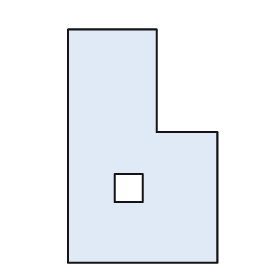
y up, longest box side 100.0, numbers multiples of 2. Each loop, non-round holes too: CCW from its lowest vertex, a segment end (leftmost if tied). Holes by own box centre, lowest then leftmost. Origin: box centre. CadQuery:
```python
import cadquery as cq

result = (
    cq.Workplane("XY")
    .moveTo(-32.0, -50.0)
    .lineTo(32.0, -50.0)
    .lineTo(32.0, 6.0)
    .lineTo(6.0, 6.0)
    .lineTo(6.0, 50.0)
    .lineTo(-32.0, 50.0)
    .close()
    .moveTo(-12.0, -24.0)
    .lineTo(0.0, -24.0)
    .lineTo(0.0, -12.0)
    .lineTo(-12.0, -12.0)
    .close()
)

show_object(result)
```